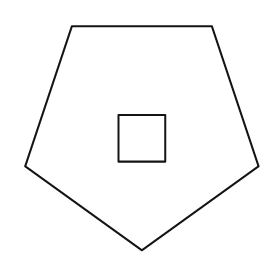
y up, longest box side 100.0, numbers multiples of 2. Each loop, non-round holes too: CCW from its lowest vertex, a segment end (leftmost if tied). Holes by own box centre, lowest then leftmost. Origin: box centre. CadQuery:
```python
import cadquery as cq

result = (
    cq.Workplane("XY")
    .moveTo(0.0, -48.0)
    .lineTo(50.0, -12.0)
    .lineTo(30.0, 48.0)
    .lineTo(-30.0, 48.0)
    .lineTo(-50.0, -12.0)
    .close()
    .moveTo(-10.0, -10.0)
    .lineTo(10.0, -10.0)
    .lineTo(10.0, 10.0)
    .lineTo(-10.0, 10.0)
    .close()
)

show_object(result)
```